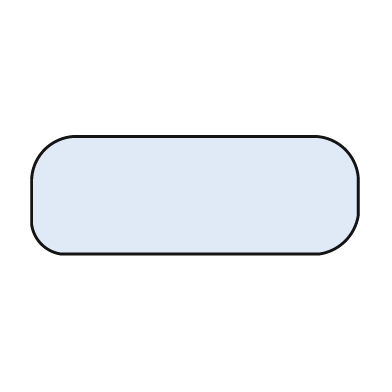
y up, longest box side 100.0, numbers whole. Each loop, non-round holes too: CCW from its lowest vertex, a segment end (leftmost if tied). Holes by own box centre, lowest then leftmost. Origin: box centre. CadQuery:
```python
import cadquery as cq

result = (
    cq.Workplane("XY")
    .moveTo(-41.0, -18.0)
    .lineTo(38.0, -18.0)
    .threePointArc((46.0, -14.0), (50.0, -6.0))
    .lineTo(50.0, 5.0)
    .threePointArc((46.0, 14.0), (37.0, 18.0))
    .lineTo(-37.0, 18.0)
    .threePointArc((-46.0, 14.0), (-50.0, 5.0))
    .lineTo(-50.0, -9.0)
    .threePointArc((-47.0, -15.0), (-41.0, -18.0))
    .close()
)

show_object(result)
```